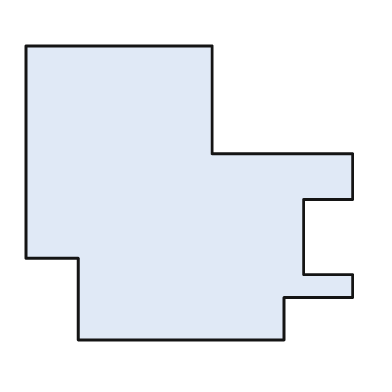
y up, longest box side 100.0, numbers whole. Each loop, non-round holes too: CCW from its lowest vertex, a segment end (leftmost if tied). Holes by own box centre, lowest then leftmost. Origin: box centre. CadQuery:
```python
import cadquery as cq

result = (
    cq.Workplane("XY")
    .moveTo(-34.0, -45.0)
    .lineTo(29.0, -45.0)
    .lineTo(29.0, -32.0)
    .lineTo(50.0, -32.0)
    .lineTo(50.0, -25.0)
    .lineTo(35.0, -25.0)
    .lineTo(35.0, -2.0)
    .lineTo(50.0, -2.0)
    .lineTo(50.0, 12.0)
    .lineTo(7.0, 12.0)
    .lineTo(7.0, 45.0)
    .lineTo(-50.0, 45.0)
    .lineTo(-50.0, -20.0)
    .lineTo(-34.0, -20.0)
    .close()
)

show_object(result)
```